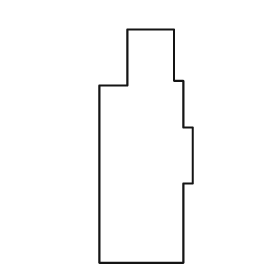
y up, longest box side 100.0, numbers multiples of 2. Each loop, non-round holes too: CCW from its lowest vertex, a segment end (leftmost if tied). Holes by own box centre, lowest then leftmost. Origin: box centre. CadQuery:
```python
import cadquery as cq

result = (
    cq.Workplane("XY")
    .moveTo(-20.0, -50.0)
    .lineTo(16.0, -50.0)
    .lineTo(16.0, -16.0)
    .lineTo(20.0, -16.0)
    .lineTo(20.0, 8.0)
    .lineTo(16.0, 8.0)
    .lineTo(16.0, 28.0)
    .lineTo(12.0, 28.0)
    .lineTo(12.0, 50.0)
    .lineTo(-8.0, 50.0)
    .lineTo(-8.0, 26.0)
    .lineTo(-20.0, 26.0)
    .close()
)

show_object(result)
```